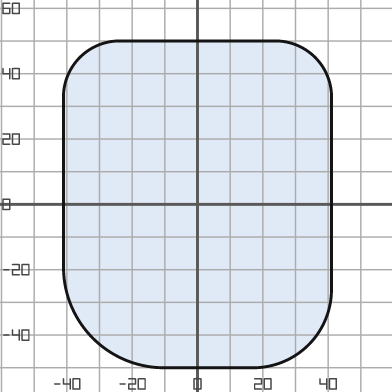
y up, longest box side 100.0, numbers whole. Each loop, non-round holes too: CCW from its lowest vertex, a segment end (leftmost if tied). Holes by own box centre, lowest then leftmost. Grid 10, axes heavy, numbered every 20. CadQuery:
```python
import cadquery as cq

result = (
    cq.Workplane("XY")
    .moveTo(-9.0, -50.0)
    .lineTo(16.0, -50.0)
    .threePointArc((34.0, -43.0), (41.0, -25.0))
    .lineTo(41.0, 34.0)
    .threePointArc((36.0, 45.0), (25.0, 50.0))
    .lineTo(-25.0, 50.0)
    .threePointArc((-36.0, 45.0), (-41.0, 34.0))
    .lineTo(-41.0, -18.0)
    .threePointArc((-32.0, -41.0), (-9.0, -50.0))
    .close()
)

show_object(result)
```